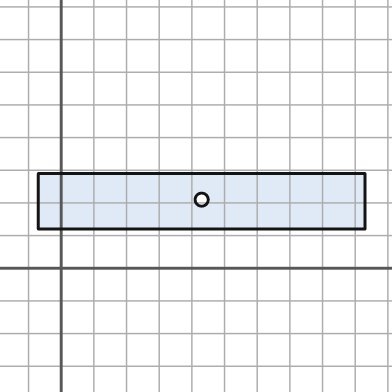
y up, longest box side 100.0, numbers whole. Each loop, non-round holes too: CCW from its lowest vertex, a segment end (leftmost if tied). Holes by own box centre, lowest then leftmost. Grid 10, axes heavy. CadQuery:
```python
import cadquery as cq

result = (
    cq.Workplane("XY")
    .moveTo(-7.0, 12.0)
    .lineTo(93.0, 12.0)
    .lineTo(93.0, 29.0)
    .lineTo(-7.0, 29.0)
    .close()
    .moveTo(43.0, 21.0)
    .circle(2.0)
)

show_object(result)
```